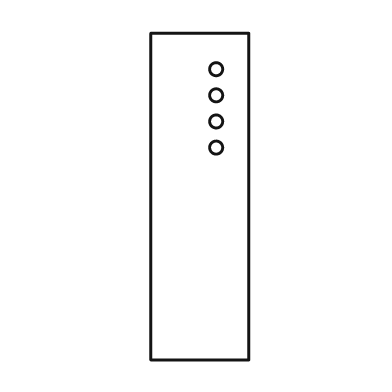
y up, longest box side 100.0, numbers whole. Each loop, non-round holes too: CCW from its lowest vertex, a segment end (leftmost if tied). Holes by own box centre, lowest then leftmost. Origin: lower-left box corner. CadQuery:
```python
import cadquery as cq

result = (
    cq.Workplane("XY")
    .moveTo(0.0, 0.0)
    .lineTo(30.0, 0.0)
    .lineTo(30.0, 100.0)
    .lineTo(0.0, 100.0)
    .close()
    .moveTo(20.0, 65.0)
    .circle(2.0)
    .moveTo(20.0, 73.0)
    .circle(2.0)
    .moveTo(20.0, 81.0)
    .circle(2.0)
    .moveTo(20.0, 89.0)
    .circle(2.0)
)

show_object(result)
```